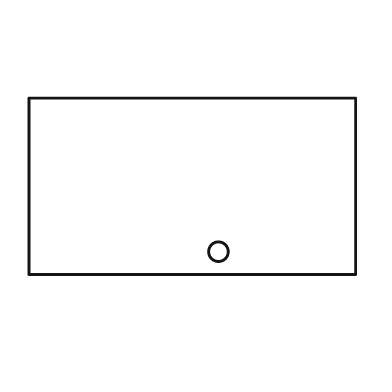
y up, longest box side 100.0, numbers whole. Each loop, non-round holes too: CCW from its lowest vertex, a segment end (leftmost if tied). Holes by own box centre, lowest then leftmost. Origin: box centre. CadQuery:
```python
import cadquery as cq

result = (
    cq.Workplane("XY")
    .moveTo(-50.0, -27.0)
    .lineTo(50.0, -27.0)
    .lineTo(50.0, 27.0)
    .lineTo(-50.0, 27.0)
    .close()
    .moveTo(8.0, -20.0)
    .circle(3.0)
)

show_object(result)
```